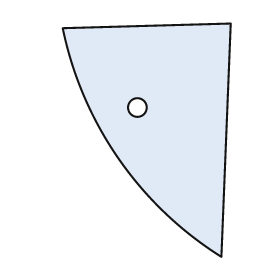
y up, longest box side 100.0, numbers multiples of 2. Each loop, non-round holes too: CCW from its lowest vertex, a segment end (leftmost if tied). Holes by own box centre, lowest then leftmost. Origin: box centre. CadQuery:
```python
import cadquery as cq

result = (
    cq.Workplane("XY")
    .moveTo(32.0, -50.0)
    .lineTo(36.0, 50.0)
    .lineTo(-36.0, 48.0)
    .threePointArc((-12.0, -8.0), (32.0, -50.0))
    .close()
    .moveTo(-4.0, 14.0)
    .circle(4.0)
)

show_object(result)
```